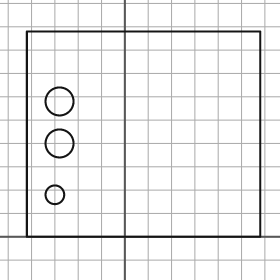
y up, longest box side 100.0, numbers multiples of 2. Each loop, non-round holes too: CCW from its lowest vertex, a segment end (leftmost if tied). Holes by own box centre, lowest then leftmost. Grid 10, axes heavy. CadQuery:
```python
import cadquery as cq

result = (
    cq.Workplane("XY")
    .moveTo(-42.0, 0.0)
    .lineTo(58.0, 0.0)
    .lineTo(58.0, 88.0)
    .lineTo(-42.0, 88.0)
    .close()
    .moveTo(-30.0, 18.0)
    .circle(4.0)
    .moveTo(-28.0, 40.0)
    .circle(6.0)
    .moveTo(-28.0, 58.0)
    .circle(6.0)
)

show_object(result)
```